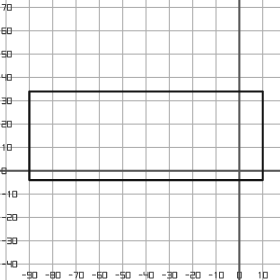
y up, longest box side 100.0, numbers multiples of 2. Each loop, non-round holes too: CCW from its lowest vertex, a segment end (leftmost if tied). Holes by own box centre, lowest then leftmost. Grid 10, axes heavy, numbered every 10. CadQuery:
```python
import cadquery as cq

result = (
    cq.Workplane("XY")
    .moveTo(-90.0, -4.0)
    .lineTo(10.0, -4.0)
    .lineTo(10.0, 34.0)
    .lineTo(-90.0, 34.0)
    .close()
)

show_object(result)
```